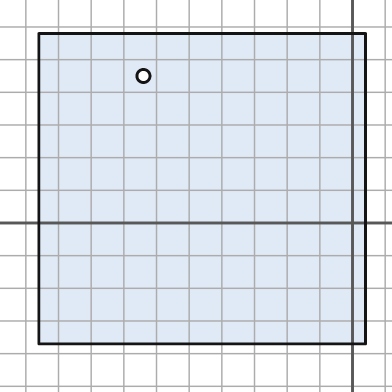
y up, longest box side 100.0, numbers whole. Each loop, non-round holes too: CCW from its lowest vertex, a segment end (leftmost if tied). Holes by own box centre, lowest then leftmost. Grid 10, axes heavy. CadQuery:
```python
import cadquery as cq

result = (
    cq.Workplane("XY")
    .moveTo(-96.0, -37.0)
    .lineTo(4.0, -37.0)
    .lineTo(4.0, 58.0)
    .lineTo(-96.0, 58.0)
    .close()
    .moveTo(-64.0, 45.0)
    .circle(2.0)
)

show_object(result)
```